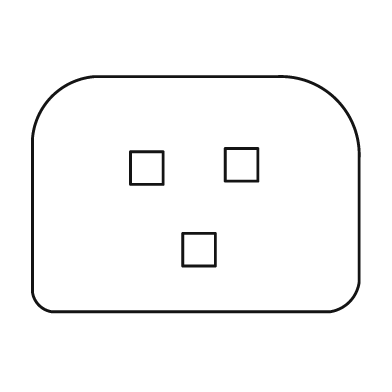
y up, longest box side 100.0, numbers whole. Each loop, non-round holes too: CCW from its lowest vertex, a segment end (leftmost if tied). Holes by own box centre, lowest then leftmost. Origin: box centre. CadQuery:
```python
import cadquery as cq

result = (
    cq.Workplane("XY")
    .moveTo(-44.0, -36.0)
    .lineTo(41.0, -36.0)
    .threePointArc((47.0, -33.0), (50.0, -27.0))
    .lineTo(50.0, 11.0)
    .threePointArc((43.0, 29.0), (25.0, 36.0))
    .lineTo(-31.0, 36.0)
    .threePointArc((-44.0, 30.0), (-50.0, 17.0))
    .lineTo(-50.0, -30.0)
    .threePointArc((-48.0, -34.0), (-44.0, -36.0))
    .close()
    .moveTo(-4.0, -22.0)
    .lineTo(6.0, -22.0)
    .lineTo(6.0, -12.0)
    .lineTo(-4.0, -12.0)
    .close()
    .moveTo(-20.0, 3.0)
    .lineTo(-10.0, 3.0)
    .lineTo(-10.0, 13.0)
    .lineTo(-20.0, 13.0)
    .close()
    .moveTo(9.0, 4.0)
    .lineTo(19.0, 4.0)
    .lineTo(19.0, 14.0)
    .lineTo(9.0, 14.0)
    .close()
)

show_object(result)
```